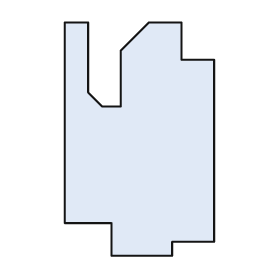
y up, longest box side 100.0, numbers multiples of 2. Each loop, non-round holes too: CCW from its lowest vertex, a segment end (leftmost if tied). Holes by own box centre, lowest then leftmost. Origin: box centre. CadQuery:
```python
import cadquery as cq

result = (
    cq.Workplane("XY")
    .moveTo(-12.0, -50.0)
    .lineTo(14.0, -50.0)
    .lineTo(14.0, -44.0)
    .lineTo(32.0, -44.0)
    .lineTo(32.0, 34.0)
    .lineTo(18.0, 34.0)
    .lineTo(18.0, 50.0)
    .lineTo(4.0, 50.0)
    .lineTo(-8.0, 38.0)
    .lineTo(-8.0, 14.0)
    .lineTo(-16.0, 14.0)
    .lineTo(-22.0, 20.0)
    .lineTo(-22.0, 50.0)
    .lineTo(-32.0, 50.0)
    .lineTo(-32.0, -36.0)
    .lineTo(-12.0, -36.0)
    .close()
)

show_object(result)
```